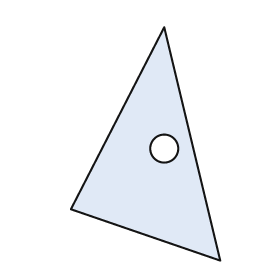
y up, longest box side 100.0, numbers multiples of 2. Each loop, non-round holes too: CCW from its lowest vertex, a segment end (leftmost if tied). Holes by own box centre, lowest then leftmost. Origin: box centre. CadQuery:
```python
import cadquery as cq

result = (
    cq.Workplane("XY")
    .moveTo(32.0, -50.0)
    .lineTo(8.0, 50.0)
    .lineTo(-32.0, -28.0)
    .close()
    .moveTo(8.0, -2.0)
    .circle(6.0)
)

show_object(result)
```